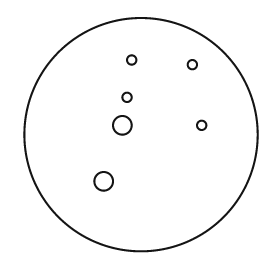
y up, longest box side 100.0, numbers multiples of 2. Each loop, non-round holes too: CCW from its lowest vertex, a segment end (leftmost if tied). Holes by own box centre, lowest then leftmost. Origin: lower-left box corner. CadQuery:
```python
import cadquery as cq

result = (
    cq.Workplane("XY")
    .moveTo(50.0, 50.0)
    .circle(50.0)
    .moveTo(34.0, 30.0)
    .circle(4.0)
    .moveTo(42.0, 54.0)
    .circle(4.0)
    .moveTo(76.0, 54.0)
    .circle(2.0)
    .moveTo(44.0, 66.0)
    .circle(2.0)
    .moveTo(72.0, 80.0)
    .circle(2.0)
    .moveTo(46.0, 82.0)
    .circle(2.0)
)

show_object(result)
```